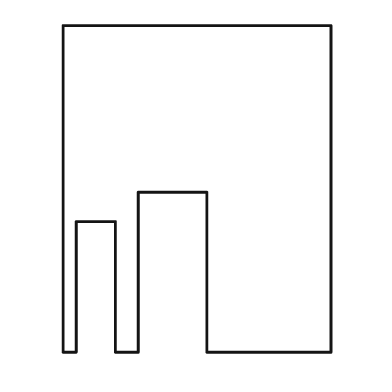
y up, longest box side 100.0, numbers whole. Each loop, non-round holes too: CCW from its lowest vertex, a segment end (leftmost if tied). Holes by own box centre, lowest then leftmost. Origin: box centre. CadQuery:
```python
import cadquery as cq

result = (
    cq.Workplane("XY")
    .moveTo(-41.0, -50.0)
    .lineTo(-37.0, -50.0)
    .lineTo(-37.0, -10.0)
    .lineTo(-25.0, -10.0)
    .lineTo(-25.0, -50.0)
    .lineTo(-18.0, -50.0)
    .lineTo(-18.0, -1.0)
    .lineTo(3.0, -1.0)
    .lineTo(3.0, -50.0)
    .lineTo(41.0, -50.0)
    .lineTo(41.0, 50.0)
    .lineTo(-41.0, 50.0)
    .close()
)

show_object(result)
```